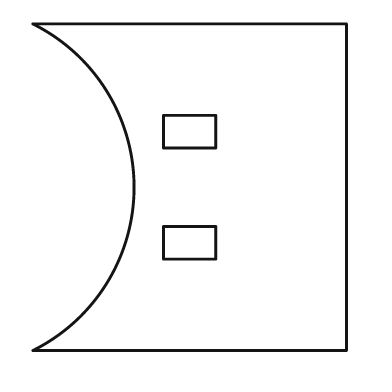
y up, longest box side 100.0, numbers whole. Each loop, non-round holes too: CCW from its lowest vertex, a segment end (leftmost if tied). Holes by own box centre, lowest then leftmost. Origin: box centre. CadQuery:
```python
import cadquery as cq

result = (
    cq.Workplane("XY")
    .moveTo(-48.0, -50.0)
    .lineTo(48.0, -50.0)
    .lineTo(48.0, 50.0)
    .lineTo(-48.0, 50.0)
    .threePointArc((-17.0, 0.0), (-48.0, -50.0))
    .close()
    .moveTo(-8.0, -22.0)
    .lineTo(8.0, -22.0)
    .lineTo(8.0, -12.0)
    .lineTo(-8.0, -12.0)
    .close()
    .moveTo(-8.0, 12.0)
    .lineTo(8.0, 12.0)
    .lineTo(8.0, 22.0)
    .lineTo(-8.0, 22.0)
    .close()
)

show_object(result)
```